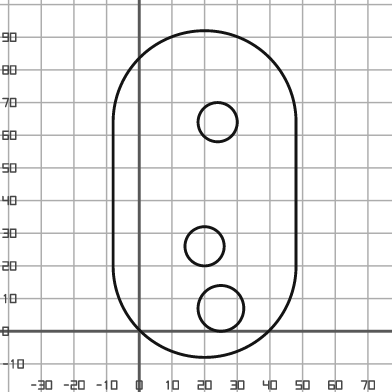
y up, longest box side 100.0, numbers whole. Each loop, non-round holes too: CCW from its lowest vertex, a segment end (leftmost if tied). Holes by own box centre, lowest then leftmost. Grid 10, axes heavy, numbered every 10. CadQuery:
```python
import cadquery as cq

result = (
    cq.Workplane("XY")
    .moveTo(-8.0, 20.0)
    .threePointArc((20.0, -8.0), (48.0, 20.0))
    .lineTo(48.0, 64.0)
    .threePointArc((20.0, 92.0), (-8.0, 64.0))
    .close()
    .moveTo(25.0, 7.0)
    .circle(7.0)
    .moveTo(20.0, 26.0)
    .circle(6.0)
    .moveTo(24.0, 64.0)
    .circle(6.0)
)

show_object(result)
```